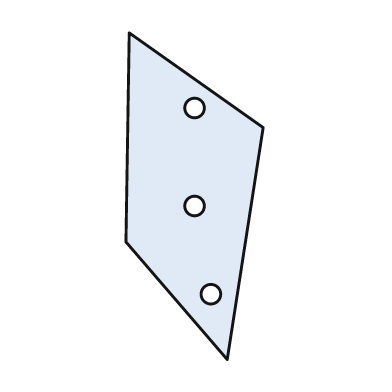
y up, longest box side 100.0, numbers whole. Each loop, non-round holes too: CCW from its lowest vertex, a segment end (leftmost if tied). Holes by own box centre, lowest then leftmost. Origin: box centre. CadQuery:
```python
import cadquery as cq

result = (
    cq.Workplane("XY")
    .moveTo(10.0, -50.0)
    .lineTo(21.0, 21.0)
    .lineTo(-20.0, 50.0)
    .lineTo(-21.0, -14.0)
    .close()
    .moveTo(5.0, -30.0)
    .circle(3.0)
    .moveTo(0.0, -3.0)
    .circle(3.0)
    .moveTo(0.0, 27.0)
    .circle(3.0)
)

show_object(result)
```